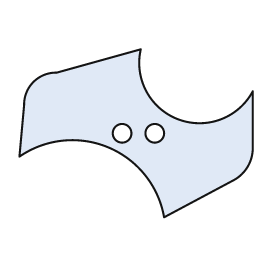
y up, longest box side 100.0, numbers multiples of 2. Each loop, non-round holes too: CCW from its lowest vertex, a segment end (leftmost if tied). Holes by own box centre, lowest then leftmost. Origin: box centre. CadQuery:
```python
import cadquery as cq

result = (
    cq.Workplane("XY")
    .moveTo(12.0, -36.0)
    .lineTo(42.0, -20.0)
    .threePointArc((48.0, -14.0), (50.0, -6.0))
    .lineTo(50.0, 18.0)
    .threePointArc((18.0, 6.0), (2.0, 36.0))
    .lineTo(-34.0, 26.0)
    .threePointArc((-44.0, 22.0), (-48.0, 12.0))
    .lineTo(-50.0, -10.0)
    .threePointArc((-12.0, -6.0), (12.0, -36.0))
    .close()
    .moveTo(-6.0, 0.0)
    .circle(4.0)
    .moveTo(8.0, 0.0)
    .circle(4.0)
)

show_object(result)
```